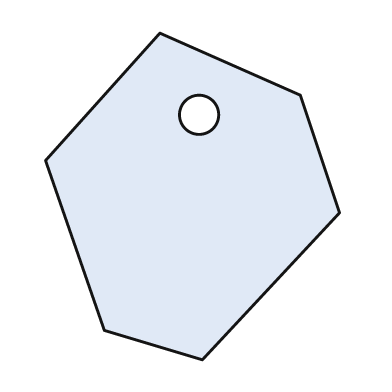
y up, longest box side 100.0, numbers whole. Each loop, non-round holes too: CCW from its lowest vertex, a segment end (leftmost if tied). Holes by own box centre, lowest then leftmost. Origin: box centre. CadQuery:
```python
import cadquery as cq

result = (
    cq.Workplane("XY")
    .moveTo(3.0, -50.0)
    .lineTo(45.0, -5.0)
    .lineTo(33.0, 31.0)
    .lineTo(-10.0, 50.0)
    .lineTo(-45.0, 11.0)
    .lineTo(-27.0, -41.0)
    .close()
    .moveTo(2.0, 25.0)
    .circle(6.0)
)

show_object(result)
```